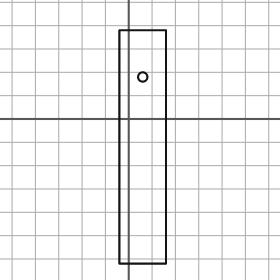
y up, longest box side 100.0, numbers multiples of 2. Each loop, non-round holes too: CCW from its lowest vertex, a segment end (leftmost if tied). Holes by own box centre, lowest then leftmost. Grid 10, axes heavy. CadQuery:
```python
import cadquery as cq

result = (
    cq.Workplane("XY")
    .moveTo(-4.0, -62.0)
    .lineTo(16.0, -62.0)
    .lineTo(16.0, 38.0)
    .lineTo(-4.0, 38.0)
    .close()
    .moveTo(6.0, 18.0)
    .circle(2.0)
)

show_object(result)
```